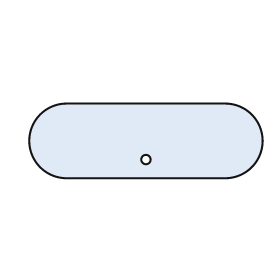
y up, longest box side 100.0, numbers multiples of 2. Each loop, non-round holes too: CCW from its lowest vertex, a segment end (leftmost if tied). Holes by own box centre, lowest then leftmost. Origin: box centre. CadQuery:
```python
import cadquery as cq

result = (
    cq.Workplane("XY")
    .moveTo(-34.0, -16.0)
    .lineTo(34.0, -16.0)
    .threePointArc((50.0, 0.0), (34.0, 16.0))
    .lineTo(-34.0, 16.0)
    .threePointArc((-50.0, 0.0), (-34.0, -16.0))
    .close()
    .moveTo(0.0, -8.0)
    .circle(2.0)
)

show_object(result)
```